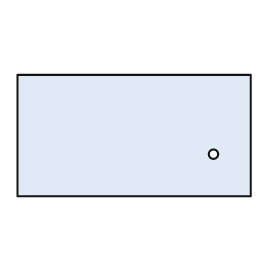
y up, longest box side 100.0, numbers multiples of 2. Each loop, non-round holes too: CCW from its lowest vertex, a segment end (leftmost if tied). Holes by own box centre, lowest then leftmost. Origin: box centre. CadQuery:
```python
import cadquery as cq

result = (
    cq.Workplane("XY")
    .moveTo(-50.0, -26.0)
    .lineTo(50.0, -26.0)
    .lineTo(50.0, 26.0)
    .lineTo(-50.0, 26.0)
    .close()
    .moveTo(34.0, -8.0)
    .circle(2.0)
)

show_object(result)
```